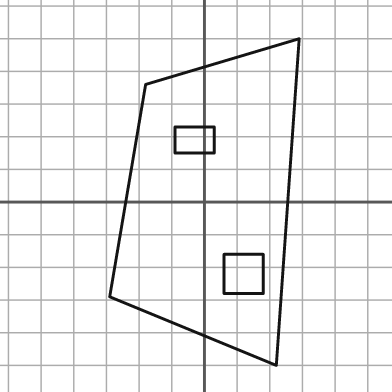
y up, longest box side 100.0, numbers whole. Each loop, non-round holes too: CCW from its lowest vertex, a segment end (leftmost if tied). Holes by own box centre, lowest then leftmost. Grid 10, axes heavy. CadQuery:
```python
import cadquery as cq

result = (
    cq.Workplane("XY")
    .moveTo(22.0, -50.0)
    .lineTo(29.0, 50.0)
    .lineTo(-18.0, 36.0)
    .lineTo(-29.0, -29.0)
    .close()
    .moveTo(6.0, -28.0)
    .lineTo(18.0, -28.0)
    .lineTo(18.0, -16.0)
    .lineTo(6.0, -16.0)
    .close()
    .moveTo(-9.0, 15.0)
    .lineTo(3.0, 15.0)
    .lineTo(3.0, 23.0)
    .lineTo(-9.0, 23.0)
    .close()
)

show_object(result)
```